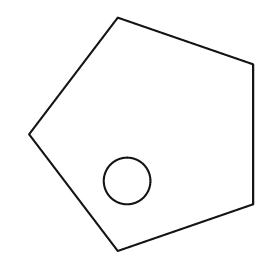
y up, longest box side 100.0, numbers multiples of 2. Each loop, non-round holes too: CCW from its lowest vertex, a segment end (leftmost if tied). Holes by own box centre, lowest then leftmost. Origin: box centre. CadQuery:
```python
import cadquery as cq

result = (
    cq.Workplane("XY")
    .moveTo(-10.0, -50.0)
    .lineTo(48.0, -30.0)
    .lineTo(48.0, 30.0)
    .lineTo(-10.0, 50.0)
    .lineTo(-48.0, 0.0)
    .close()
    .moveTo(-6.0, -20.0)
    .circle(10.0)
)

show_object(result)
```